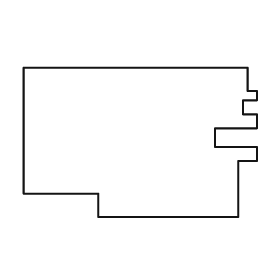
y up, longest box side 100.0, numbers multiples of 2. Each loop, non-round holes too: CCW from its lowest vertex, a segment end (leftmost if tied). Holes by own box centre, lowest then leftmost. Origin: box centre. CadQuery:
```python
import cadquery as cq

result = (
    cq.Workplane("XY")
    .moveTo(-18.0, -32.0)
    .lineTo(42.0, -32.0)
    .lineTo(42.0, -8.0)
    .lineTo(50.0, -8.0)
    .lineTo(50.0, -2.0)
    .lineTo(32.0, -2.0)
    .lineTo(32.0, 6.0)
    .lineTo(50.0, 6.0)
    .lineTo(50.0, 12.0)
    .lineTo(44.0, 12.0)
    .lineTo(44.0, 18.0)
    .lineTo(50.0, 18.0)
    .lineTo(50.0, 22.0)
    .lineTo(46.0, 22.0)
    .lineTo(46.0, 32.0)
    .lineTo(-50.0, 32.0)
    .lineTo(-50.0, -22.0)
    .lineTo(-18.0, -22.0)
    .close()
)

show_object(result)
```